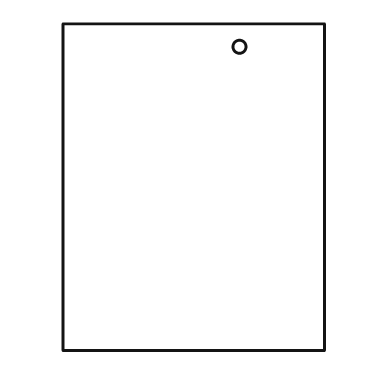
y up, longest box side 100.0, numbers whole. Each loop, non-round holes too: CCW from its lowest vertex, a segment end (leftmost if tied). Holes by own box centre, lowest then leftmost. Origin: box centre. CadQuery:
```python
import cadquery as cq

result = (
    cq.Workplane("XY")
    .moveTo(-40.0, -50.0)
    .lineTo(40.0, -50.0)
    .lineTo(40.0, 50.0)
    .lineTo(-40.0, 50.0)
    .close()
    .moveTo(14.0, 43.0)
    .circle(2.0)
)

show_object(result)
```